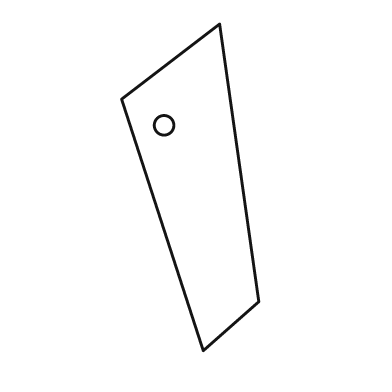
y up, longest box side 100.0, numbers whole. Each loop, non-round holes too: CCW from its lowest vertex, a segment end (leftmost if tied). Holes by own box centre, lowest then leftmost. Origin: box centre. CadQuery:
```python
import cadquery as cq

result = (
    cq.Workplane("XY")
    .moveTo(4.0, -50.0)
    .lineTo(21.0, -35.0)
    .lineTo(9.0, 50.0)
    .lineTo(-21.0, 27.0)
    .close()
    .moveTo(-8.0, 19.0)
    .circle(3.0)
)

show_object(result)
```